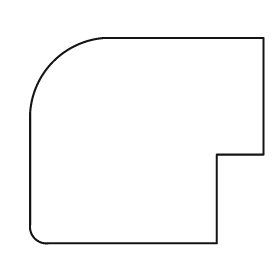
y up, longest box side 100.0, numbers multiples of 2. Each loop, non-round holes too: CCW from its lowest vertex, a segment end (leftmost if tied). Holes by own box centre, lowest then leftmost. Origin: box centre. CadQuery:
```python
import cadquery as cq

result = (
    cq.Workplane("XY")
    .moveTo(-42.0, -44.0)
    .lineTo(30.0, -44.0)
    .lineTo(30.0, -6.0)
    .lineTo(50.0, -6.0)
    .lineTo(50.0, 44.0)
    .lineTo(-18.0, 44.0)
    .threePointArc((-40.0, 34.0), (-50.0, 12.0))
    .lineTo(-50.0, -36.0)
    .threePointArc((-48.0, -42.0), (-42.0, -44.0))
    .close()
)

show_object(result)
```